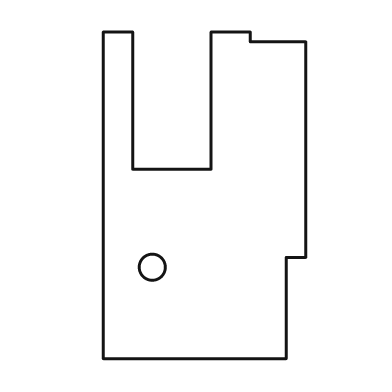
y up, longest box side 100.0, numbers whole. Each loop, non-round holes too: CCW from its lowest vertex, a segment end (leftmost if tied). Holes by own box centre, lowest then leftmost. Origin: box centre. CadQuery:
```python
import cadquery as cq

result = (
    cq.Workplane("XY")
    .moveTo(-31.0, -50.0)
    .lineTo(25.0, -50.0)
    .lineTo(25.0, -19.0)
    .lineTo(31.0, -19.0)
    .lineTo(31.0, 47.0)
    .lineTo(14.0, 47.0)
    .lineTo(14.0, 50.0)
    .lineTo(2.0, 50.0)
    .lineTo(2.0, 8.0)
    .lineTo(-22.0, 8.0)
    .lineTo(-22.0, 50.0)
    .lineTo(-31.0, 50.0)
    .close()
    .moveTo(-16.0, -22.0)
    .circle(4.0)
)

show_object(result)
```